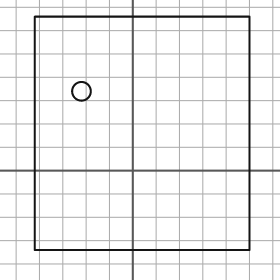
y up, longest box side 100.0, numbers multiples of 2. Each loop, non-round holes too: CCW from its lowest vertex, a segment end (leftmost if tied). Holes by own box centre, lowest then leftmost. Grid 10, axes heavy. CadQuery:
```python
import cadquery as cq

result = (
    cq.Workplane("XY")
    .moveTo(-42.0, -34.0)
    .lineTo(50.0, -34.0)
    .lineTo(50.0, 66.0)
    .lineTo(-42.0, 66.0)
    .close()
    .moveTo(-22.0, 34.0)
    .circle(4.0)
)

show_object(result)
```